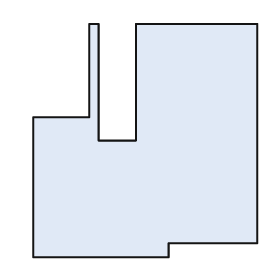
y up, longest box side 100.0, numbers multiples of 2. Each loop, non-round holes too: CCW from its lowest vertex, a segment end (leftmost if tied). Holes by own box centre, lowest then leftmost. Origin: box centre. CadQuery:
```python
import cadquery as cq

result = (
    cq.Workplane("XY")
    .moveTo(-48.0, -50.0)
    .lineTo(10.0, -50.0)
    .lineTo(10.0, -44.0)
    .lineTo(48.0, -44.0)
    .lineTo(48.0, 50.0)
    .lineTo(-4.0, 50.0)
    .lineTo(-4.0, 0.0)
    .lineTo(-20.0, 0.0)
    .lineTo(-20.0, 50.0)
    .lineTo(-24.0, 50.0)
    .lineTo(-24.0, 10.0)
    .lineTo(-48.0, 10.0)
    .close()
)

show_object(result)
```